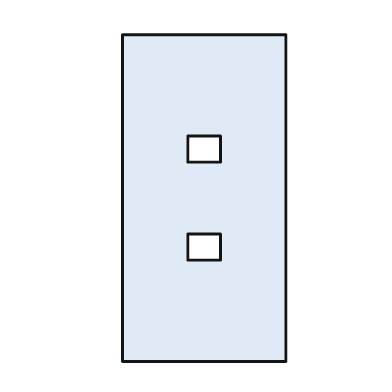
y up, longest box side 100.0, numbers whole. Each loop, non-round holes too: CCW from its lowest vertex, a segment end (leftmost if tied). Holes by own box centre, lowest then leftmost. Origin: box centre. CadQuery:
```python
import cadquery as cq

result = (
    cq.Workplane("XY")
    .moveTo(-25.0, -50.0)
    .lineTo(25.0, -50.0)
    .lineTo(25.0, 50.0)
    .lineTo(-25.0, 50.0)
    .close()
    .moveTo(-5.0, -19.0)
    .lineTo(5.0, -19.0)
    .lineTo(5.0, -11.0)
    .lineTo(-5.0, -11.0)
    .close()
    .moveTo(-5.0, 11.0)
    .lineTo(5.0, 11.0)
    .lineTo(5.0, 19.0)
    .lineTo(-5.0, 19.0)
    .close()
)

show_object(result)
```